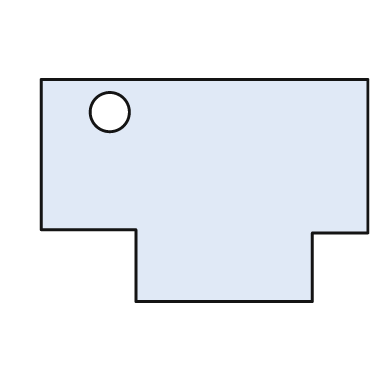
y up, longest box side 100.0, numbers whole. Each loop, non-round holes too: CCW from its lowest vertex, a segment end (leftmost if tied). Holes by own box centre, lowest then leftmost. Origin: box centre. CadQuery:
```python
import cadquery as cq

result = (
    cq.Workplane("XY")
    .moveTo(-21.0, -34.0)
    .lineTo(33.0, -34.0)
    .lineTo(33.0, -13.0)
    .lineTo(50.0, -13.0)
    .lineTo(50.0, 34.0)
    .lineTo(-50.0, 34.0)
    .lineTo(-50.0, -12.0)
    .lineTo(-21.0, -12.0)
    .close()
    .moveTo(-29.0, 24.0)
    .circle(6.0)
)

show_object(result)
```